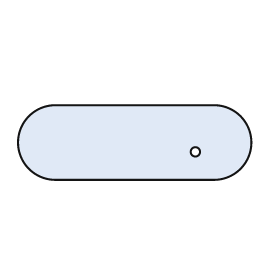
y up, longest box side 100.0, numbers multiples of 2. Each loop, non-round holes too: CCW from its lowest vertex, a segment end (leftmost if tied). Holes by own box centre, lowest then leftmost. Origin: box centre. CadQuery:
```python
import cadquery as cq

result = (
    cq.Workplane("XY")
    .moveTo(-34.0, -16.0)
    .lineTo(34.0, -16.0)
    .threePointArc((50.0, 0.0), (34.0, 16.0))
    .lineTo(-34.0, 16.0)
    .threePointArc((-50.0, 0.0), (-34.0, -16.0))
    .close()
    .moveTo(26.0, -4.0)
    .circle(2.0)
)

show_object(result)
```